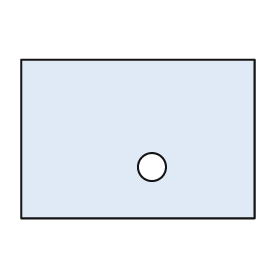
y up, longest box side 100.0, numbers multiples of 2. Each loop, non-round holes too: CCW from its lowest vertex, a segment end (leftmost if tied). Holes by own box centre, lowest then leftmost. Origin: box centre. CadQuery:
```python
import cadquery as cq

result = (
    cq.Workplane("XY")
    .moveTo(-50.0, -34.0)
    .lineTo(50.0, -34.0)
    .lineTo(50.0, 34.0)
    .lineTo(-50.0, 34.0)
    .close()
    .moveTo(6.0, -12.0)
    .circle(6.0)
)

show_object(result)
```